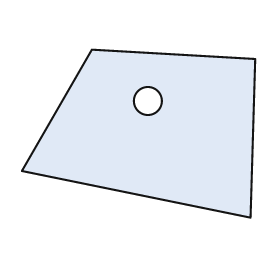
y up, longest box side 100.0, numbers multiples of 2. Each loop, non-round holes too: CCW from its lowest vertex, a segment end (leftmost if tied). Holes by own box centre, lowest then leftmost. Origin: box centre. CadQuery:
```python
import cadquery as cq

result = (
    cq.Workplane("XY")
    .moveTo(48.0, -36.0)
    .lineTo(50.0, 32.0)
    .lineTo(-20.0, 36.0)
    .lineTo(-50.0, -16.0)
    .close()
    .moveTo(4.0, 14.0)
    .circle(6.0)
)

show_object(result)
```